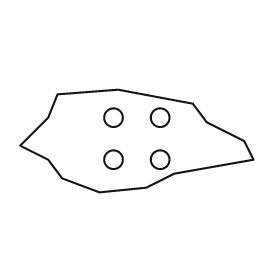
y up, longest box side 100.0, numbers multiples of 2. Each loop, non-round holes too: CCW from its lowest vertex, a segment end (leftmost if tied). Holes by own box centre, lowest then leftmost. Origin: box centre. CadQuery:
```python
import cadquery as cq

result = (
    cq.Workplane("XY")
    .moveTo(-16.0, -22.0)
    .lineTo(4.0, -20.0)
    .lineTo(16.0, -14.0)
    .lineTo(50.0, -8.0)
    .lineTo(46.0, 0.0)
    .lineTo(30.0, 8.0)
    .lineTo(24.0, 16.0)
    .lineTo(-8.0, 22.0)
    .lineTo(-34.0, 20.0)
    .lineTo(-38.0, 10.0)
    .lineTo(-50.0, -2.0)
    .lineTo(-38.0, -8.0)
    .lineTo(-32.0, -16.0)
    .close()
    .moveTo(-10.0, -8.0)
    .circle(4.0)
    .moveTo(10.0, -8.0)
    .circle(4.0)
    .moveTo(-10.0, 10.0)
    .circle(4.0)
    .moveTo(10.0, 10.0)
    .circle(4.0)
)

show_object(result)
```